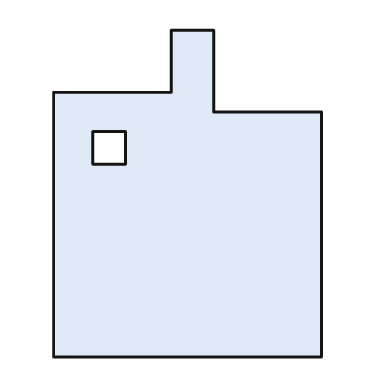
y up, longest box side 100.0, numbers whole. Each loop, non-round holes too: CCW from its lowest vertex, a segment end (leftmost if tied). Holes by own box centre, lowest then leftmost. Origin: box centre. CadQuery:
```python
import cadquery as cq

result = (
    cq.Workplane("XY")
    .moveTo(-41.0, -50.0)
    .lineTo(41.0, -50.0)
    .lineTo(41.0, 25.0)
    .lineTo(8.0, 25.0)
    .lineTo(8.0, 50.0)
    .lineTo(-5.0, 50.0)
    .lineTo(-5.0, 31.0)
    .lineTo(-41.0, 31.0)
    .close()
    .moveTo(-29.0, 9.0)
    .lineTo(-19.0, 9.0)
    .lineTo(-19.0, 19.0)
    .lineTo(-29.0, 19.0)
    .close()
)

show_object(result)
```